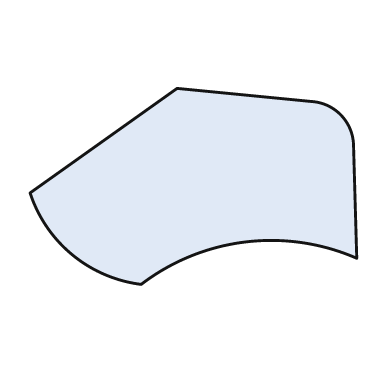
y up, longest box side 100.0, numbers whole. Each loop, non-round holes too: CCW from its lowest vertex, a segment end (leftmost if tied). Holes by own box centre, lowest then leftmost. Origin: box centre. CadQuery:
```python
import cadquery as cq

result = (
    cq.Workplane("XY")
    .moveTo(-16.0, -30.0)
    .threePointArc((16.0, -17.0), (50.0, -22.0))
    .lineTo(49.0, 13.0)
    .threePointArc((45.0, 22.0), (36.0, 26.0))
    .lineTo(-5.0, 30.0)
    .lineTo(-50.0, -2.0)
    .threePointArc((-37.0, -21.0), (-16.0, -30.0))
    .close()
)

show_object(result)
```